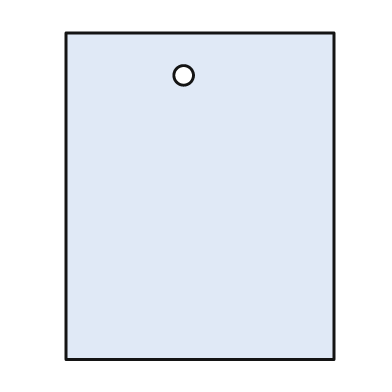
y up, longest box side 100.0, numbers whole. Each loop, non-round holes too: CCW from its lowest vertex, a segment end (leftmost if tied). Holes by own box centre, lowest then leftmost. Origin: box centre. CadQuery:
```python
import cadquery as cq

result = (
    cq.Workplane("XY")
    .moveTo(-41.0, -50.0)
    .lineTo(41.0, -50.0)
    .lineTo(41.0, 50.0)
    .lineTo(-41.0, 50.0)
    .close()
    .moveTo(-5.0, 37.0)
    .circle(3.0)
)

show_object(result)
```